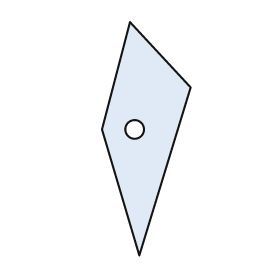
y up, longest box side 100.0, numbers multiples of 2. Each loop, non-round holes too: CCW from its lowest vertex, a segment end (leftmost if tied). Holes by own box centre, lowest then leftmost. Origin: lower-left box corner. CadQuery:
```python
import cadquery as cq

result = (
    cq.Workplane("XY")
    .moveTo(16.0, 0.0)
    .lineTo(38.0, 72.0)
    .lineTo(12.0, 100.0)
    .lineTo(0.0, 54.0)
    .close()
    .moveTo(14.0, 54.0)
    .circle(4.0)
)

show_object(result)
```